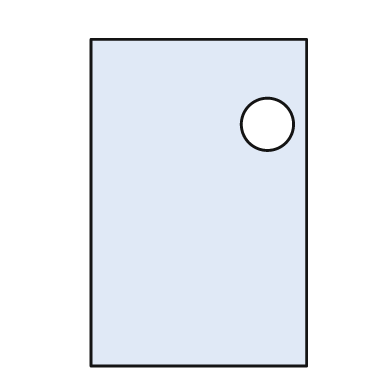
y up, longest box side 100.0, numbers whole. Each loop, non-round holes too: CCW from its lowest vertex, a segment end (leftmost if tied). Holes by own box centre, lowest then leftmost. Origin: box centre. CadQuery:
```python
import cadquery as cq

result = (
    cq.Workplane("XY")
    .moveTo(-33.0, -50.0)
    .lineTo(33.0, -50.0)
    .lineTo(33.0, 50.0)
    .lineTo(-33.0, 50.0)
    .close()
    .moveTo(21.0, 24.0)
    .circle(8.0)
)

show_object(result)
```